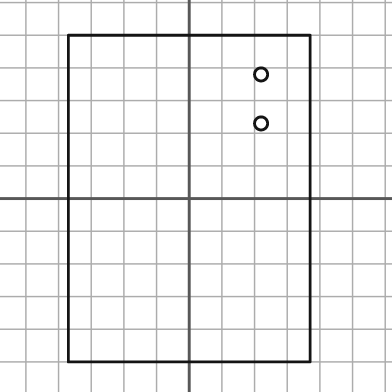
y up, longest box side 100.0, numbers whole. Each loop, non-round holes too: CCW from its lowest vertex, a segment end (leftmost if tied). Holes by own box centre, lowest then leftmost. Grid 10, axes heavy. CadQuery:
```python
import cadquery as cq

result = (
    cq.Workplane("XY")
    .moveTo(-37.0, -50.0)
    .lineTo(37.0, -50.0)
    .lineTo(37.0, 50.0)
    .lineTo(-37.0, 50.0)
    .close()
    .moveTo(22.0, 23.0)
    .circle(2.0)
    .moveTo(22.0, 38.0)
    .circle(2.0)
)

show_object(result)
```